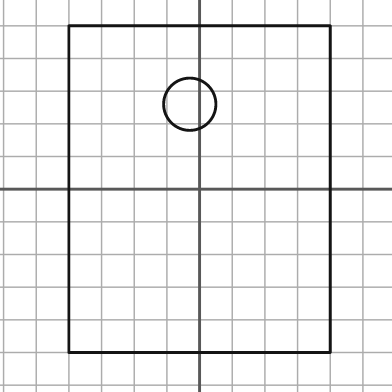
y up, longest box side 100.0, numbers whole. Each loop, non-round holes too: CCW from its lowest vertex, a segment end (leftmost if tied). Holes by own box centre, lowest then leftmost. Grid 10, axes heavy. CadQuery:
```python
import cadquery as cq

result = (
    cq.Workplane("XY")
    .moveTo(-40.0, -50.0)
    .lineTo(40.0, -50.0)
    .lineTo(40.0, 50.0)
    .lineTo(-40.0, 50.0)
    .close()
    .moveTo(-3.0, 26.0)
    .circle(8.0)
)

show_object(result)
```